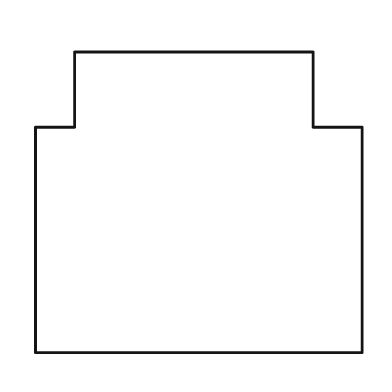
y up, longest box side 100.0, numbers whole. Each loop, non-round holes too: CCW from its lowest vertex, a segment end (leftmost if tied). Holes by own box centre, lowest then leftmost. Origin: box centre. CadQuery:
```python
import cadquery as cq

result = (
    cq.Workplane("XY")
    .moveTo(-50.0, -46.0)
    .lineTo(50.0, -46.0)
    .lineTo(50.0, 23.0)
    .lineTo(35.0, 23.0)
    .lineTo(35.0, 46.0)
    .lineTo(-38.0, 46.0)
    .lineTo(-38.0, 23.0)
    .lineTo(-50.0, 23.0)
    .close()
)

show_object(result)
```